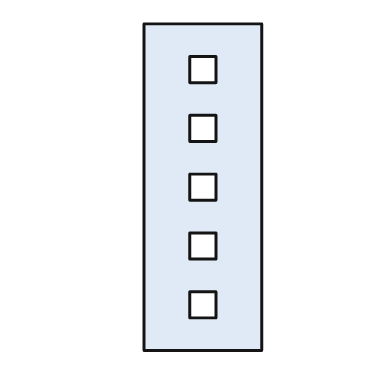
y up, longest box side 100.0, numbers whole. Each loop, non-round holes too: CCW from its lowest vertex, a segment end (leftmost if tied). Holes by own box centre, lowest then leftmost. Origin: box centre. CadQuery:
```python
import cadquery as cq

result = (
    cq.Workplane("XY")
    .moveTo(-18.0, -50.0)
    .lineTo(18.0, -50.0)
    .lineTo(18.0, 50.0)
    .lineTo(-18.0, 50.0)
    .close()
    .moveTo(-4.0, -40.0)
    .lineTo(4.0, -40.0)
    .lineTo(4.0, -32.0)
    .lineTo(-4.0, -32.0)
    .close()
    .moveTo(-4.0, -22.0)
    .lineTo(4.0, -22.0)
    .lineTo(4.0, -14.0)
    .lineTo(-4.0, -14.0)
    .close()
    .moveTo(-4.0, -4.0)
    .lineTo(4.0, -4.0)
    .lineTo(4.0, 4.0)
    .lineTo(-4.0, 4.0)
    .close()
    .moveTo(-4.0, 14.0)
    .lineTo(4.0, 14.0)
    .lineTo(4.0, 22.0)
    .lineTo(-4.0, 22.0)
    .close()
    .moveTo(-4.0, 32.0)
    .lineTo(4.0, 32.0)
    .lineTo(4.0, 40.0)
    .lineTo(-4.0, 40.0)
    .close()
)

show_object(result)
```